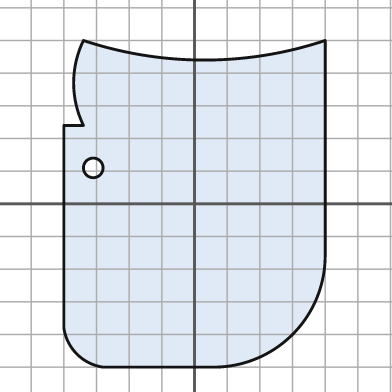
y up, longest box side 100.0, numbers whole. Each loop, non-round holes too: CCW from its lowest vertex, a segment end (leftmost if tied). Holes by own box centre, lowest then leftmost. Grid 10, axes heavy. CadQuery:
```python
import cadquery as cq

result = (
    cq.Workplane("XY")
    .moveTo(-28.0, -50.0)
    .lineTo(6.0, -50.0)
    .threePointArc((30.0, -40.0), (40.0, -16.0))
    .lineTo(40.0, 50.0)
    .threePointArc((3.0, 44.0), (-34.0, 50.0))
    .threePointArc((-37.0, 37.0), (-34.0, 24.0))
    .lineTo(-40.0, 24.0)
    .lineTo(-40.0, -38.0)
    .threePointArc((-36.0, -46.0), (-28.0, -50.0))
    .close()
    .moveTo(-31.0, 11.0)
    .circle(3.0)
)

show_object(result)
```